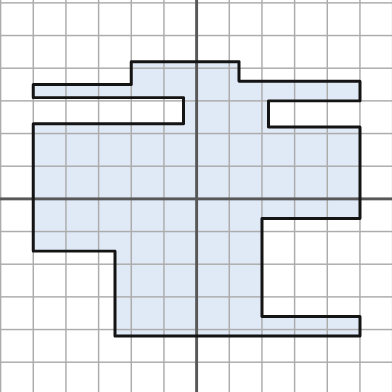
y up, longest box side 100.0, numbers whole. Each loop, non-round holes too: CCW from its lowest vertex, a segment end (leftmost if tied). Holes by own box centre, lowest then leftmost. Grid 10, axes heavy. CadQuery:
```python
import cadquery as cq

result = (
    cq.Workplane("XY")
    .moveTo(-25.0, -42.0)
    .lineTo(50.0, -42.0)
    .lineTo(50.0, -36.0)
    .lineTo(20.0, -36.0)
    .lineTo(20.0, -6.0)
    .lineTo(50.0, -6.0)
    .lineTo(50.0, 22.0)
    .lineTo(22.0, 22.0)
    .lineTo(22.0, 30.0)
    .lineTo(50.0, 30.0)
    .lineTo(50.0, 36.0)
    .lineTo(13.0, 36.0)
    .lineTo(13.0, 42.0)
    .lineTo(-20.0, 42.0)
    .lineTo(-20.0, 35.0)
    .lineTo(-50.0, 35.0)
    .lineTo(-50.0, 31.0)
    .lineTo(-4.0, 31.0)
    .lineTo(-4.0, 23.0)
    .lineTo(-50.0, 23.0)
    .lineTo(-50.0, -16.0)
    .lineTo(-25.0, -16.0)
    .close()
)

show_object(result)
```